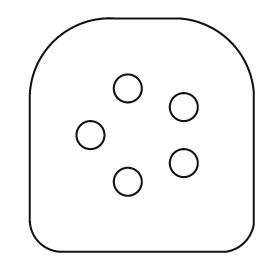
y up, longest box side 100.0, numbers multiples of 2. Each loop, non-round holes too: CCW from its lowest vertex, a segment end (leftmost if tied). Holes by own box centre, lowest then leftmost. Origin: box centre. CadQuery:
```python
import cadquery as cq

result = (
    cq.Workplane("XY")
    .moveTo(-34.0, -50.0)
    .lineTo(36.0, -50.0)
    .threePointArc((44.0, -46.0), (48.0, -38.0))
    .lineTo(48.0, 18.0)
    .threePointArc((38.0, 40.0), (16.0, 50.0))
    .lineTo(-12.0, 50.0)
    .threePointArc((-38.0, 40.0), (-48.0, 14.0))
    .lineTo(-48.0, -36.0)
    .threePointArc((-44.0, -46.0), (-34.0, -50.0))
    .close()
    .moveTo(-6.0, -20.0)
    .circle(6.0)
    .moveTo(18.0, -12.0)
    .circle(6.0)
    .moveTo(-22.0, 0.0)
    .circle(6.0)
    .moveTo(18.0, 12.0)
    .circle(6.0)
    .moveTo(-6.0, 20.0)
    .circle(6.0)
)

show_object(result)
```